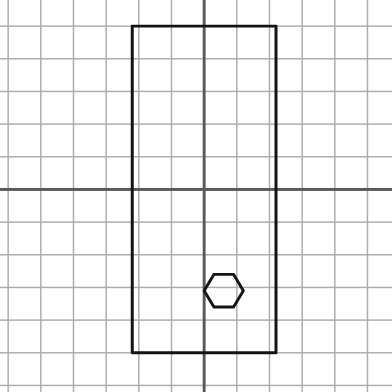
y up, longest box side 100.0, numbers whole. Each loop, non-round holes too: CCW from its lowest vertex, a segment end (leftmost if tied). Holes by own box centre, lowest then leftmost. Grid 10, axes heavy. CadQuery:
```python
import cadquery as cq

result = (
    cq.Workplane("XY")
    .moveTo(-22.0, -50.0)
    .lineTo(22.0, -50.0)
    .lineTo(22.0, 50.0)
    .lineTo(-22.0, 50.0)
    .close()
    .moveTo(3.0, -36.0)
    .lineTo(9.0, -36.0)
    .lineTo(12.0, -31.0)
    .lineTo(9.0, -26.0)
    .lineTo(3.0, -26.0)
    .lineTo(0.0, -31.0)
    .close()
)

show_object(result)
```